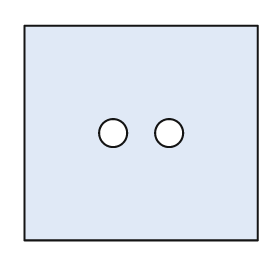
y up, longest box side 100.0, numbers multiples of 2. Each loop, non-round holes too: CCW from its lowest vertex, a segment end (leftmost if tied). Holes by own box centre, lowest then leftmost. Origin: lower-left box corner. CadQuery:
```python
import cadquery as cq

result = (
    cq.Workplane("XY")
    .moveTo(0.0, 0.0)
    .lineTo(100.0, 0.0)
    .lineTo(100.0, 92.0)
    .lineTo(0.0, 92.0)
    .close()
    .moveTo(38.0, 46.0)
    .circle(6.0)
    .moveTo(62.0, 46.0)
    .circle(6.0)
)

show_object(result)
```